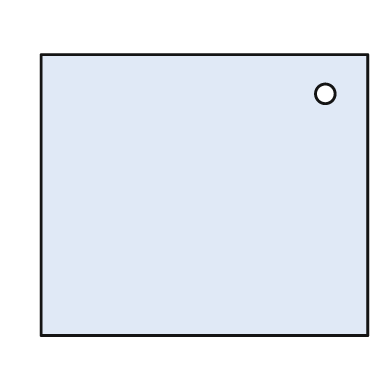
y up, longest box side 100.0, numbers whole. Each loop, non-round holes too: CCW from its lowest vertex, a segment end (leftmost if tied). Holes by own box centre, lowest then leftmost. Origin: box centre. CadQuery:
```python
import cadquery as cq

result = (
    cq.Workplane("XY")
    .moveTo(-50.0, -43.0)
    .lineTo(50.0, -43.0)
    .lineTo(50.0, 43.0)
    .lineTo(-50.0, 43.0)
    .close()
    .moveTo(37.0, 31.0)
    .circle(3.0)
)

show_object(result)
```